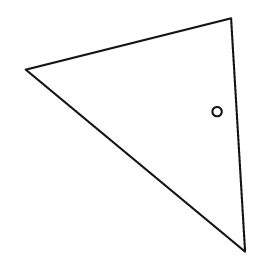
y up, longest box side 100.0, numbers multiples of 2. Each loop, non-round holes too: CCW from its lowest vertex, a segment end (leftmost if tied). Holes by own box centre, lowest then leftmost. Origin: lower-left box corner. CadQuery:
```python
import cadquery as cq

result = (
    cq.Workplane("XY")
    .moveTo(94.0, 0.0)
    .lineTo(88.0, 100.0)
    .lineTo(0.0, 78.0)
    .close()
    .moveTo(82.0, 60.0)
    .circle(2.0)
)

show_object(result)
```